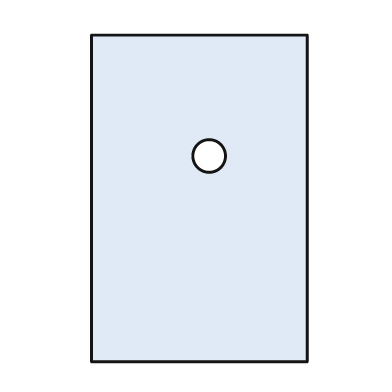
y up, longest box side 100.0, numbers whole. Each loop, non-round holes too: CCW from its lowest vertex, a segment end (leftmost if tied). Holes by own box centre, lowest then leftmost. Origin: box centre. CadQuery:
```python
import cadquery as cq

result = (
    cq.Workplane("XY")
    .moveTo(-33.0, -50.0)
    .lineTo(33.0, -50.0)
    .lineTo(33.0, 50.0)
    .lineTo(-33.0, 50.0)
    .close()
    .moveTo(3.0, 13.0)
    .circle(5.0)
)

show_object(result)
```